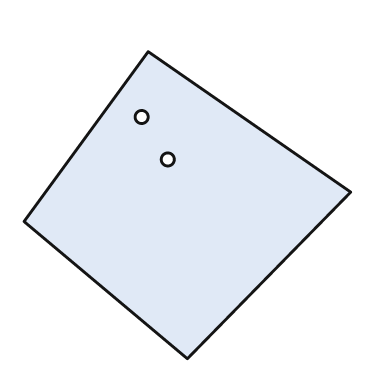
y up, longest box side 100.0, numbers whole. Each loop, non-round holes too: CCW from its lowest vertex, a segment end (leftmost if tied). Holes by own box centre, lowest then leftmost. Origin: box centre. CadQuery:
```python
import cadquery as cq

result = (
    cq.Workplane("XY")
    .moveTo(0.0, -47.0)
    .lineTo(50.0, 4.0)
    .lineTo(-12.0, 47.0)
    .lineTo(-50.0, -5.0)
    .close()
    .moveTo(-6.0, 14.0)
    .circle(2.0)
    .moveTo(-14.0, 27.0)
    .circle(2.0)
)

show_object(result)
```